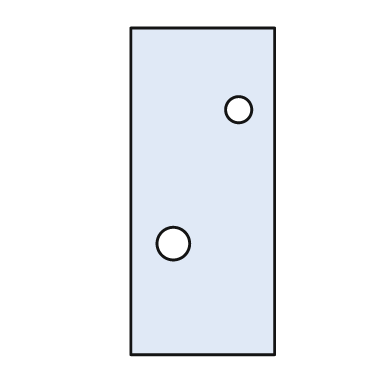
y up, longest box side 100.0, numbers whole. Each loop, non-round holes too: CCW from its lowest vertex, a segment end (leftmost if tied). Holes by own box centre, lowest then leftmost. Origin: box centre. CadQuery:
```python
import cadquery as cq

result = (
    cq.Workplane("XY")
    .moveTo(-22.0, -50.0)
    .lineTo(22.0, -50.0)
    .lineTo(22.0, 50.0)
    .lineTo(-22.0, 50.0)
    .close()
    .moveTo(-9.0, -16.0)
    .circle(5.0)
    .moveTo(11.0, 25.0)
    .circle(4.0)
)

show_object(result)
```